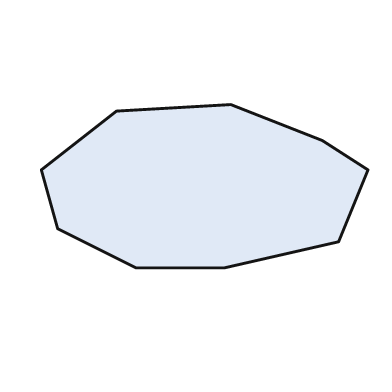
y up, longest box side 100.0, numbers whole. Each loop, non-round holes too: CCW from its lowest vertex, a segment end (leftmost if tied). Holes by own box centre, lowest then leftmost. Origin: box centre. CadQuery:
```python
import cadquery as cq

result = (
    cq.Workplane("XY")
    .moveTo(-21.0, -25.0)
    .lineTo(6.0, -25.0)
    .lineTo(41.0, -17.0)
    .lineTo(50.0, 5.0)
    .lineTo(36.0, 14.0)
    .lineTo(8.0, 25.0)
    .lineTo(-27.0, 23.0)
    .lineTo(-50.0, 5.0)
    .lineTo(-45.0, -13.0)
    .close()
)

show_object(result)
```